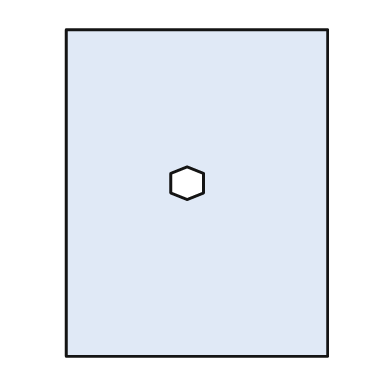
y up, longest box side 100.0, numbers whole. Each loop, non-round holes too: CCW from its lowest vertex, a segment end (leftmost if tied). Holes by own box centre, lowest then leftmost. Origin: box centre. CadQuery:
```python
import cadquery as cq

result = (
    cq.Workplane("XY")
    .moveTo(-40.0, -50.0)
    .lineTo(40.0, -50.0)
    .lineTo(40.0, 50.0)
    .lineTo(-40.0, 50.0)
    .close()
    .moveTo(-3.0, -2.0)
    .lineTo(2.0, 0.0)
    .lineTo(2.0, 6.0)
    .lineTo(-3.0, 8.0)
    .lineTo(-8.0, 6.0)
    .lineTo(-8.0, 0.0)
    .close()
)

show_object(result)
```